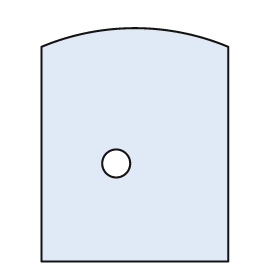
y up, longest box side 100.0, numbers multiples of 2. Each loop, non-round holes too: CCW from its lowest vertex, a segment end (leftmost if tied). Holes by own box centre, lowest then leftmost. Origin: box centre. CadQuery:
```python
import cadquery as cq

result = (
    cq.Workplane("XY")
    .moveTo(-40.0, -50.0)
    .lineTo(40.0, -50.0)
    .lineTo(40.0, 42.0)
    .threePointArc((0.0, 50.0), (-40.0, 42.0))
    .close()
    .moveTo(-8.0, -8.0)
    .circle(6.0)
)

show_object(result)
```